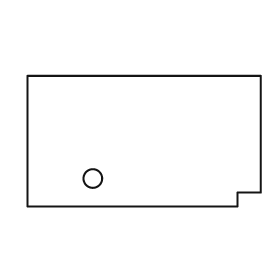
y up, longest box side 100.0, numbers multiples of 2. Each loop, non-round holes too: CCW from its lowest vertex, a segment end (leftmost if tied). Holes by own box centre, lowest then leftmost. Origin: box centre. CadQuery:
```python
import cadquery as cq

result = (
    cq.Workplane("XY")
    .moveTo(-50.0, -28.0)
    .lineTo(40.0, -28.0)
    .lineTo(40.0, -22.0)
    .lineTo(50.0, -22.0)
    .lineTo(50.0, 28.0)
    .lineTo(-50.0, 28.0)
    .close()
    .moveTo(-22.0, -16.0)
    .circle(4.0)
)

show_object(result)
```